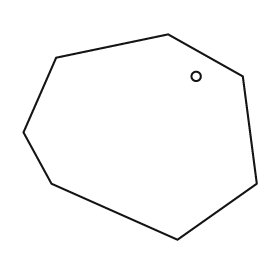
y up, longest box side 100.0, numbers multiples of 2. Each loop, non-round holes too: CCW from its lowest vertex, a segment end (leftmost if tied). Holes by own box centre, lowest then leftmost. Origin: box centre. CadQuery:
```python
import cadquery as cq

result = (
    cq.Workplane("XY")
    .moveTo(16.0, -44.0)
    .lineTo(50.0, -20.0)
    .lineTo(44.0, 26.0)
    .lineTo(12.0, 44.0)
    .lineTo(-36.0, 34.0)
    .lineTo(-50.0, 2.0)
    .lineTo(-38.0, -20.0)
    .close()
    .moveTo(24.0, 26.0)
    .circle(2.0)
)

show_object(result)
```